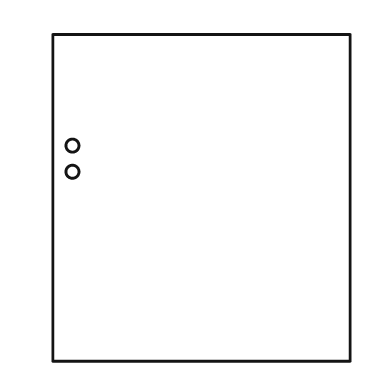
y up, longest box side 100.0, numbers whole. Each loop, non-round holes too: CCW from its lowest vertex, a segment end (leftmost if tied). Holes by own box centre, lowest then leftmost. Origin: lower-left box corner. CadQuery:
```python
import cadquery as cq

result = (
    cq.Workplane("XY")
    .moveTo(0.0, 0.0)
    .lineTo(91.0, 0.0)
    .lineTo(91.0, 100.0)
    .lineTo(0.0, 100.0)
    .close()
    .moveTo(6.0, 58.0)
    .circle(2.0)
    .moveTo(6.0, 66.0)
    .circle(2.0)
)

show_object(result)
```